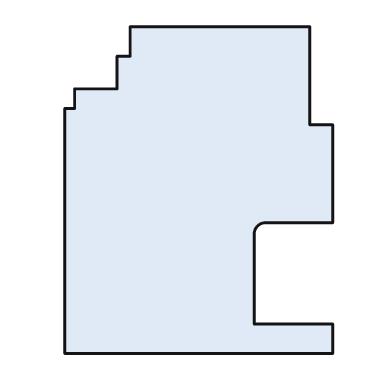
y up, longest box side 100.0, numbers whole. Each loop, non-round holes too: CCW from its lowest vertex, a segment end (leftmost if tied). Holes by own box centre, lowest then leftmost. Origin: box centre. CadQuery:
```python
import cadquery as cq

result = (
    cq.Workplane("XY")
    .moveTo(-41.0, -50.0)
    .lineTo(41.0, -50.0)
    .lineTo(41.0, -41.0)
    .lineTo(17.0, -41.0)
    .lineTo(17.0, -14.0)
    .threePointArc((18.0, -11.0), (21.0, -10.0))
    .lineTo(41.0, -10.0)
    .lineTo(41.0, 20.0)
    .lineTo(34.0, 20.0)
    .lineTo(34.0, 50.0)
    .lineTo(-21.0, 50.0)
    .lineTo(-21.0, 41.0)
    .lineTo(-25.0, 41.0)
    .lineTo(-25.0, 31.0)
    .lineTo(-38.0, 31.0)
    .lineTo(-38.0, 25.0)
    .lineTo(-41.0, 25.0)
    .close()
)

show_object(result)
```